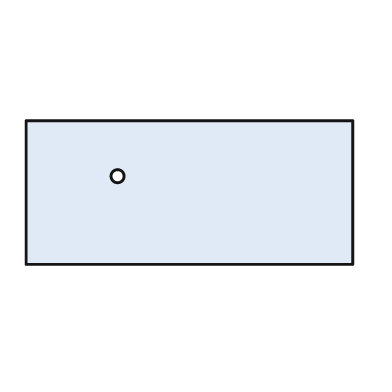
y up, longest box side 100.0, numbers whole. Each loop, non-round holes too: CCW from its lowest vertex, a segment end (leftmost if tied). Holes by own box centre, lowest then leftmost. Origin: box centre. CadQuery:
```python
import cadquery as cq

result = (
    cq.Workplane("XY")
    .moveTo(-50.0, -22.0)
    .lineTo(50.0, -22.0)
    .lineTo(50.0, 22.0)
    .lineTo(-50.0, 22.0)
    .close()
    .moveTo(-22.0, 5.0)
    .circle(2.0)
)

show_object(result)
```